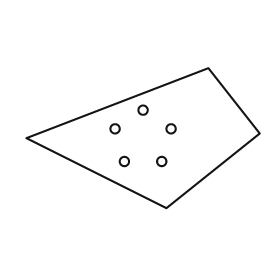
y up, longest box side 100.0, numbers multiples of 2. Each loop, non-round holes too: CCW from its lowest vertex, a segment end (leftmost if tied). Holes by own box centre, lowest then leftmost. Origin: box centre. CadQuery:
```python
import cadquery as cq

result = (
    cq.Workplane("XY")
    .moveTo(10.0, -30.0)
    .lineTo(50.0, 2.0)
    .lineTo(28.0, 30.0)
    .lineTo(-50.0, 0.0)
    .close()
    .moveTo(-8.0, -10.0)
    .circle(2.0)
    .moveTo(8.0, -10.0)
    .circle(2.0)
    .moveTo(-12.0, 4.0)
    .circle(2.0)
    .moveTo(12.0, 4.0)
    .circle(2.0)
    .moveTo(0.0, 12.0)
    .circle(2.0)
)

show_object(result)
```